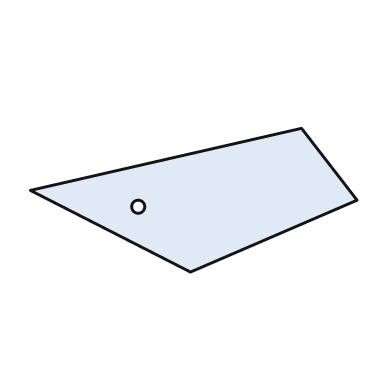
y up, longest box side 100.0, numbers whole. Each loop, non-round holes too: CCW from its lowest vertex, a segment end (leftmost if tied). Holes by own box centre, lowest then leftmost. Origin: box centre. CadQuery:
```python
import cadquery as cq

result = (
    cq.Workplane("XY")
    .moveTo(-1.0, -22.0)
    .lineTo(50.0, 0.0)
    .lineTo(33.0, 22.0)
    .lineTo(-50.0, 3.0)
    .close()
    .moveTo(-17.0, -2.0)
    .circle(2.0)
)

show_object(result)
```